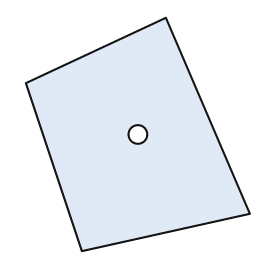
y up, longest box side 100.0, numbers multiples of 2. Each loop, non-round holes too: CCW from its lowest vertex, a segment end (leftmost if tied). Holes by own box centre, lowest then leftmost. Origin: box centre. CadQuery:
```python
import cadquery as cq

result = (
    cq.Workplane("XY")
    .moveTo(-24.0, -50.0)
    .lineTo(48.0, -34.0)
    .lineTo(12.0, 50.0)
    .lineTo(-48.0, 22.0)
    .close()
    .moveTo(0.0, 0.0)
    .circle(4.0)
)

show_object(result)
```